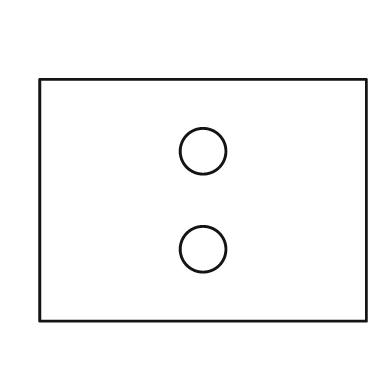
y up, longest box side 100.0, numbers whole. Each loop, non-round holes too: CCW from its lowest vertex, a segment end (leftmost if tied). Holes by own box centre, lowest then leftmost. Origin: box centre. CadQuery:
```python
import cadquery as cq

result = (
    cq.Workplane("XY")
    .moveTo(-50.0, -37.0)
    .lineTo(50.0, -37.0)
    .lineTo(50.0, 37.0)
    .lineTo(-50.0, 37.0)
    .close()
    .moveTo(0.0, -15.0)
    .circle(7.0)
    .moveTo(0.0, 15.0)
    .circle(7.0)
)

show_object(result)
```